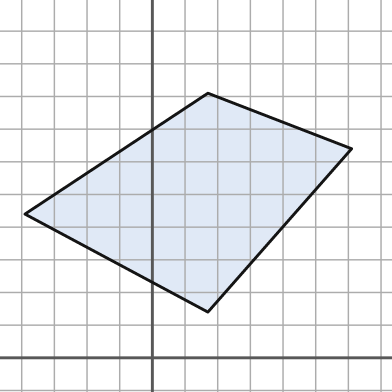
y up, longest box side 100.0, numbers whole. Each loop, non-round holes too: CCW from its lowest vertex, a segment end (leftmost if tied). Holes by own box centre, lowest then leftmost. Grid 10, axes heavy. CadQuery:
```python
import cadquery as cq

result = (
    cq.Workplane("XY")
    .moveTo(17.0, 14.0)
    .lineTo(61.0, 64.0)
    .lineTo(17.0, 81.0)
    .lineTo(-39.0, 44.0)
    .close()
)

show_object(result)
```